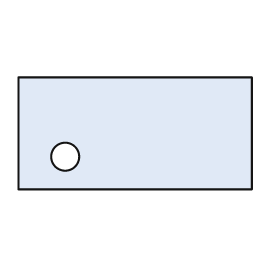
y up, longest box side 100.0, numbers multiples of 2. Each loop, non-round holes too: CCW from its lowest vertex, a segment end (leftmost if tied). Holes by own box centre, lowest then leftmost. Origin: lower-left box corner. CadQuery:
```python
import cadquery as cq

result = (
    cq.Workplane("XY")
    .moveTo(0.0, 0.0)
    .lineTo(100.0, 0.0)
    .lineTo(100.0, 48.0)
    .lineTo(0.0, 48.0)
    .close()
    .moveTo(20.0, 14.0)
    .circle(6.0)
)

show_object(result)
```